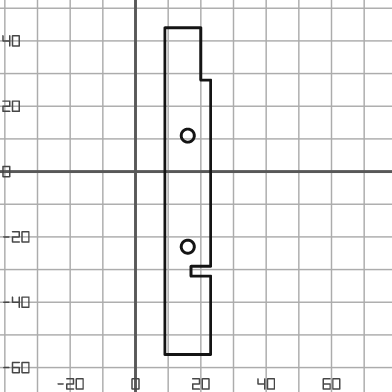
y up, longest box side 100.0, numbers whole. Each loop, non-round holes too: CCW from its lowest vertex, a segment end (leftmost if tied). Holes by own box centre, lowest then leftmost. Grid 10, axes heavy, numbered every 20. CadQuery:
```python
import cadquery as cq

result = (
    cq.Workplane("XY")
    .moveTo(9.0, -56.0)
    .lineTo(23.0, -56.0)
    .lineTo(23.0, -32.0)
    .lineTo(17.0, -32.0)
    .lineTo(17.0, -29.0)
    .lineTo(23.0, -29.0)
    .lineTo(23.0, 28.0)
    .lineTo(20.0, 28.0)
    .lineTo(20.0, 44.0)
    .lineTo(9.0, 44.0)
    .close()
    .moveTo(16.0, -23.0)
    .circle(2.0)
    .moveTo(16.0, 11.0)
    .circle(2.0)
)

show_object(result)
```